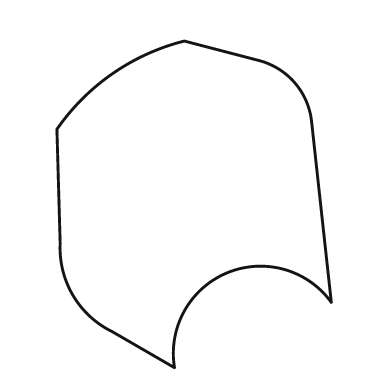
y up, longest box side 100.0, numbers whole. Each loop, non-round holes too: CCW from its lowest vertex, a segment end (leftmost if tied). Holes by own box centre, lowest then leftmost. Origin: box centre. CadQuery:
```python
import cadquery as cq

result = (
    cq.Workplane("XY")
    .moveTo(-6.0, -50.0)
    .threePointArc((10.0, -21.0), (42.0, -30.0))
    .lineTo(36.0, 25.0)
    .threePointArc((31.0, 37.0), (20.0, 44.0))
    .lineTo(-3.0, 50.0)
    .threePointArc((-25.0, 40.0), (-42.0, 23.0))
    .lineTo(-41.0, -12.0)
    .threePointArc((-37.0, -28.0), (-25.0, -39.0))
    .close()
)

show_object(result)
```